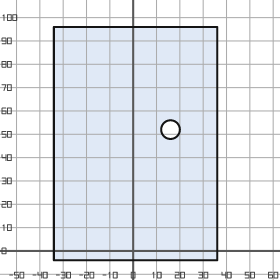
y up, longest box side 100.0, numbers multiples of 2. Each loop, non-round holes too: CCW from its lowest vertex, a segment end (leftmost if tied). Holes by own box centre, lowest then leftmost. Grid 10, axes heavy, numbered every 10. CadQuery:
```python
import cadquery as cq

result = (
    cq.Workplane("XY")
    .moveTo(-34.0, -4.0)
    .lineTo(36.0, -4.0)
    .lineTo(36.0, 96.0)
    .lineTo(-34.0, 96.0)
    .close()
    .moveTo(16.0, 52.0)
    .circle(4.0)
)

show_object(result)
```